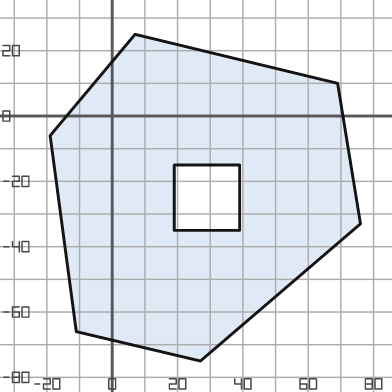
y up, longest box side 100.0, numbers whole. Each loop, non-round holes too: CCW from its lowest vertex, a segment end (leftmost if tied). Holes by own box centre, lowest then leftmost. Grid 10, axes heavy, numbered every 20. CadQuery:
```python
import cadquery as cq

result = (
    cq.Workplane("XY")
    .moveTo(27.0, -75.0)
    .lineTo(76.0, -33.0)
    .lineTo(69.0, 10.0)
    .lineTo(7.0, 25.0)
    .lineTo(-19.0, -6.0)
    .lineTo(-11.0, -66.0)
    .close()
    .moveTo(19.0, -35.0)
    .lineTo(39.0, -35.0)
    .lineTo(39.0, -15.0)
    .lineTo(19.0, -15.0)
    .close()
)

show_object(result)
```